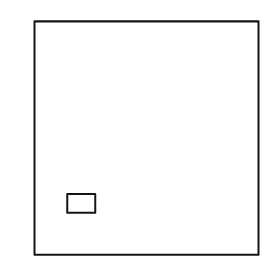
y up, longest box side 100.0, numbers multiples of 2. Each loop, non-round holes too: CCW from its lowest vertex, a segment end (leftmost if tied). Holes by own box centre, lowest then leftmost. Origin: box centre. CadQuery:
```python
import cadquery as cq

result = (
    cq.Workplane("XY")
    .moveTo(-48.0, -50.0)
    .lineTo(48.0, -50.0)
    .lineTo(48.0, 50.0)
    .lineTo(-48.0, 50.0)
    .close()
    .moveTo(-34.0, -32.0)
    .lineTo(-22.0, -32.0)
    .lineTo(-22.0, -24.0)
    .lineTo(-34.0, -24.0)
    .close()
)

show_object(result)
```